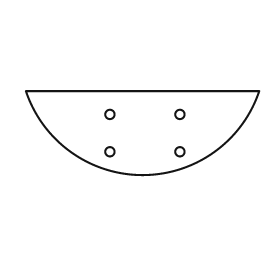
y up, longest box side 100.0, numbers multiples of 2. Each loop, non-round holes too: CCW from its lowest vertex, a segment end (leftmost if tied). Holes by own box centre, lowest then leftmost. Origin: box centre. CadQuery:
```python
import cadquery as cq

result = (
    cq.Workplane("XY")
    .moveTo(-50.0, 18.0)
    .threePointArc((0.0, -18.0), (50.0, 18.0))
    .close()
    .moveTo(-14.0, -8.0)
    .circle(2.0)
    .moveTo(16.0, -8.0)
    .circle(2.0)
    .moveTo(-14.0, 8.0)
    .circle(2.0)
    .moveTo(16.0, 8.0)
    .circle(2.0)
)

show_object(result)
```